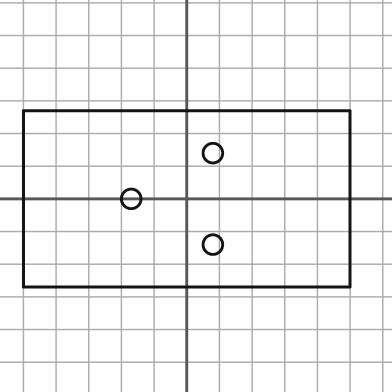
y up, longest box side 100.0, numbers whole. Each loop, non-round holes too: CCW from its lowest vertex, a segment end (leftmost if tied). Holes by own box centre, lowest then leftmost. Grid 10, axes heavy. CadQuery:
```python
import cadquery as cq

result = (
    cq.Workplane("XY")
    .moveTo(-50.0, -27.0)
    .lineTo(50.0, -27.0)
    .lineTo(50.0, 27.0)
    .lineTo(-50.0, 27.0)
    .close()
    .moveTo(8.0, -14.0)
    .circle(3.0)
    .moveTo(-17.0, 0.0)
    .circle(3.0)
    .moveTo(8.0, 14.0)
    .circle(3.0)
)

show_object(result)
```